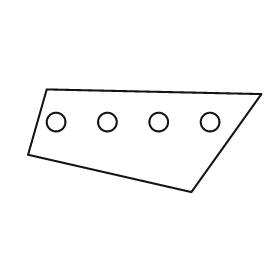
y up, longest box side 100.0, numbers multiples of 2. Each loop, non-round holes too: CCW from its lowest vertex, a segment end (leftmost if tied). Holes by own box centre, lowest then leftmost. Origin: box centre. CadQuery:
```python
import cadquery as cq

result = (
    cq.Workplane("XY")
    .moveTo(20.0, -22.0)
    .lineTo(50.0, 20.0)
    .lineTo(-42.0, 22.0)
    .lineTo(-50.0, -6.0)
    .close()
    .moveTo(-38.0, 8.0)
    .circle(4.0)
    .moveTo(-16.0, 8.0)
    .circle(4.0)
    .moveTo(6.0, 8.0)
    .circle(4.0)
    .moveTo(28.0, 8.0)
    .circle(4.0)
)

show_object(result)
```